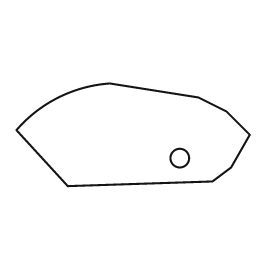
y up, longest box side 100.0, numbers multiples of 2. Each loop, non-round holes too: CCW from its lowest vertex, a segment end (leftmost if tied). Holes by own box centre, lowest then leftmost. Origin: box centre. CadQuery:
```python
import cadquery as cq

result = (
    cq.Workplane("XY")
    .moveTo(-28.0, -22.0)
    .lineTo(34.0, -20.0)
    .lineTo(42.0, -14.0)
    .lineTo(50.0, 0.0)
    .lineTo(40.0, 10.0)
    .lineTo(28.0, 16.0)
    .lineTo(-10.0, 22.0)
    .threePointArc((-32.0, 16.0), (-50.0, 2.0))
    .close()
    .moveTo(20.0, -10.0)
    .circle(4.0)
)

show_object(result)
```